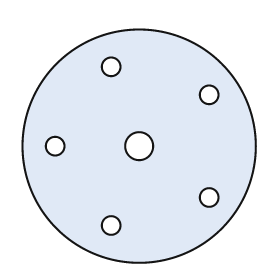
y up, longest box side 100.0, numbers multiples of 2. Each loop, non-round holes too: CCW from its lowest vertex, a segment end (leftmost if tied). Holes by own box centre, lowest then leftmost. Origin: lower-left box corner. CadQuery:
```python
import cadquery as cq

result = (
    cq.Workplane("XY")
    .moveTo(50.0, 50.0)
    .circle(50.0)
    .moveTo(38.0, 16.0)
    .circle(4.0)
    .moveTo(80.0, 28.0)
    .circle(4.0)
    .moveTo(14.0, 50.0)
    .circle(4.0)
    .moveTo(50.0, 50.0)
    .circle(6.0)
    .moveTo(80.0, 72.0)
    .circle(4.0)
    .moveTo(38.0, 84.0)
    .circle(4.0)
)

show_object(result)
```